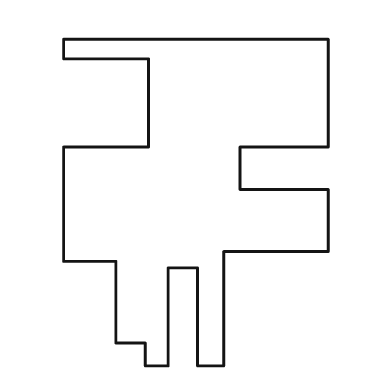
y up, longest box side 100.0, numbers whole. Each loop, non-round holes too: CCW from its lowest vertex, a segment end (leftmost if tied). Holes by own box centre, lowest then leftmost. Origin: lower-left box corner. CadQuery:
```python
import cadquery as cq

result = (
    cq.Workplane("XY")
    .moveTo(25.0, 0.0)
    .lineTo(32.0, 0.0)
    .lineTo(32.0, 30.0)
    .lineTo(41.0, 30.0)
    .lineTo(41.0, 0.0)
    .lineTo(49.0, 0.0)
    .lineTo(49.0, 35.0)
    .lineTo(81.0, 35.0)
    .lineTo(81.0, 54.0)
    .lineTo(54.0, 54.0)
    .lineTo(54.0, 67.0)
    .lineTo(81.0, 67.0)
    .lineTo(81.0, 100.0)
    .lineTo(0.0, 100.0)
    .lineTo(0.0, 94.0)
    .lineTo(26.0, 94.0)
    .lineTo(26.0, 67.0)
    .lineTo(0.0, 67.0)
    .lineTo(0.0, 32.0)
    .lineTo(16.0, 32.0)
    .lineTo(16.0, 7.0)
    .lineTo(25.0, 7.0)
    .close()
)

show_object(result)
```